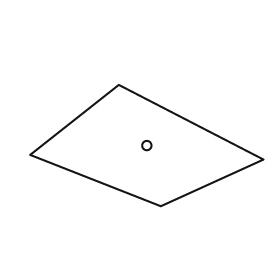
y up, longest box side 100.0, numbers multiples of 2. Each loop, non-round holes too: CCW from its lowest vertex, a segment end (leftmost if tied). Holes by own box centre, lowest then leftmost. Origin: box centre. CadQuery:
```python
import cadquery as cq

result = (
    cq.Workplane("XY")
    .moveTo(6.0, -26.0)
    .lineTo(50.0, -6.0)
    .lineTo(-12.0, 26.0)
    .lineTo(-50.0, -4.0)
    .close()
    .moveTo(0.0, 0.0)
    .circle(2.0)
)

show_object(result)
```